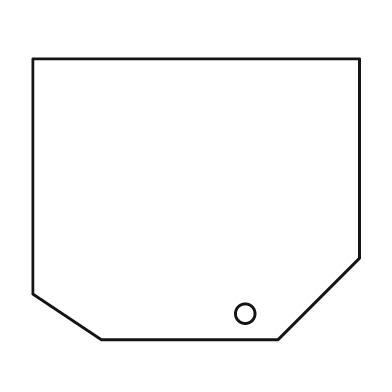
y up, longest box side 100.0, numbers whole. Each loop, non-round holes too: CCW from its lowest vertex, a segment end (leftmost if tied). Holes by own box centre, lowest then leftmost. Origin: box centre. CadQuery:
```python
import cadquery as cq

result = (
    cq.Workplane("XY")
    .moveTo(-29.0, -43.0)
    .lineTo(25.0, -43.0)
    .lineTo(50.0, -18.0)
    .lineTo(50.0, 43.0)
    .lineTo(-50.0, 43.0)
    .lineTo(-50.0, -29.0)
    .close()
    .moveTo(15.0, -35.0)
    .circle(3.0)
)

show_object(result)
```